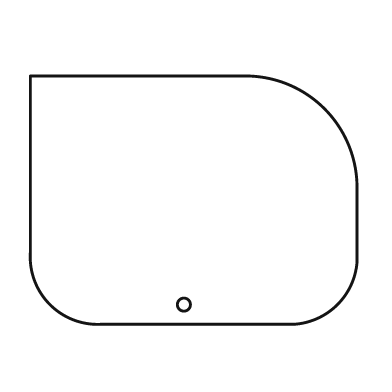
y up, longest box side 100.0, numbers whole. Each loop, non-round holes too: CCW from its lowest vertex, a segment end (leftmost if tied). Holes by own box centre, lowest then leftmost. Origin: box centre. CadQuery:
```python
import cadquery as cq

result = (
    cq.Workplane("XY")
    .moveTo(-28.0, -38.0)
    .lineTo(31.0, -38.0)
    .threePointArc((44.0, -32.0), (50.0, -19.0))
    .lineTo(50.0, 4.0)
    .threePointArc((40.0, 28.0), (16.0, 38.0))
    .lineTo(-50.0, 38.0)
    .lineTo(-50.0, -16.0)
    .threePointArc((-44.0, -32.0), (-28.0, -38.0))
    .close()
    .moveTo(-3.0, -32.0)
    .circle(2.0)
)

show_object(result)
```